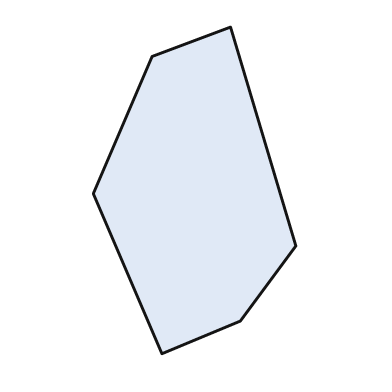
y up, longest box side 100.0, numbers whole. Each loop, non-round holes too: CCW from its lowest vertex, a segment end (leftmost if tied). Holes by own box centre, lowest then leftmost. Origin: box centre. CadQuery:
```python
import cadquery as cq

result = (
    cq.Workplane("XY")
    .moveTo(-10.0, -50.0)
    .lineTo(14.0, -40.0)
    .lineTo(31.0, -17.0)
    .lineTo(11.0, 50.0)
    .lineTo(-13.0, 41.0)
    .lineTo(-31.0, -1.0)
    .close()
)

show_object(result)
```